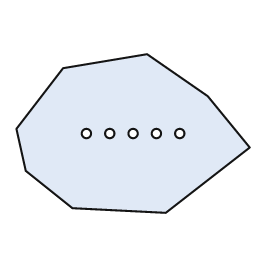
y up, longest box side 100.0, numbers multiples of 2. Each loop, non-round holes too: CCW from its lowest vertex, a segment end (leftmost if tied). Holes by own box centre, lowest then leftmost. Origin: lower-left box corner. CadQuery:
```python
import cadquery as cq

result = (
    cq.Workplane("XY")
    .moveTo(64.0, 0.0)
    .lineTo(100.0, 28.0)
    .lineTo(82.0, 50.0)
    .lineTo(56.0, 68.0)
    .lineTo(20.0, 62.0)
    .lineTo(0.0, 36.0)
    .lineTo(4.0, 18.0)
    .lineTo(24.0, 2.0)
    .close()
    .moveTo(30.0, 34.0)
    .circle(2.0)
    .moveTo(40.0, 34.0)
    .circle(2.0)
    .moveTo(50.0, 34.0)
    .circle(2.0)
    .moveTo(60.0, 34.0)
    .circle(2.0)
    .moveTo(70.0, 34.0)
    .circle(2.0)
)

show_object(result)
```